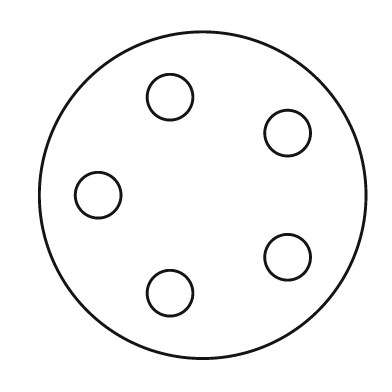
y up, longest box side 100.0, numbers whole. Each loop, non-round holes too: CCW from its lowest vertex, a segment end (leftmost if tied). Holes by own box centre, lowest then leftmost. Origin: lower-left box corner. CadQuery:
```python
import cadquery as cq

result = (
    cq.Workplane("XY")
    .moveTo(50.0, 50.0)
    .circle(50.0)
    .moveTo(40.0, 20.0)
    .circle(7.0)
    .moveTo(76.0, 31.0)
    .circle(7.0)
    .moveTo(18.0, 50.0)
    .circle(7.0)
    .moveTo(76.0, 69.0)
    .circle(7.0)
    .moveTo(40.0, 80.0)
    .circle(7.0)
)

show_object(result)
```